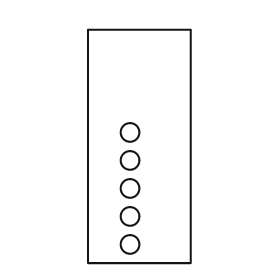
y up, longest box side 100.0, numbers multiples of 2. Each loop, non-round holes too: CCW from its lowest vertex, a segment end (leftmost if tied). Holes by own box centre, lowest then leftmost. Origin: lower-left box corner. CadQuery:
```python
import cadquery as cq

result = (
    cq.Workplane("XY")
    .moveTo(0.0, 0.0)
    .lineTo(44.0, 0.0)
    .lineTo(44.0, 100.0)
    .lineTo(0.0, 100.0)
    .close()
    .moveTo(18.0, 8.0)
    .circle(4.0)
    .moveTo(18.0, 20.0)
    .circle(4.0)
    .moveTo(18.0, 32.0)
    .circle(4.0)
    .moveTo(18.0, 44.0)
    .circle(4.0)
    .moveTo(18.0, 56.0)
    .circle(4.0)
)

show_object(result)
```